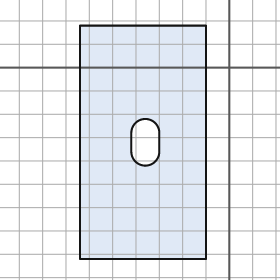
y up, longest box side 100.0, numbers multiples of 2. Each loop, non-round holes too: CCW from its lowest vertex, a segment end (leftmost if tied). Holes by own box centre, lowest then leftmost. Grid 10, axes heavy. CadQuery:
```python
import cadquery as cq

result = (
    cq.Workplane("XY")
    .moveTo(-64.0, -82.0)
    .lineTo(-10.0, -82.0)
    .lineTo(-10.0, 18.0)
    .lineTo(-64.0, 18.0)
    .close()
    .moveTo(-42.0, -36.0)
    .threePointArc((-36.0, -42.0), (-30.0, -36.0))
    .lineTo(-30.0, -28.0)
    .threePointArc((-36.0, -22.0), (-42.0, -28.0))
    .close()
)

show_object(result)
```